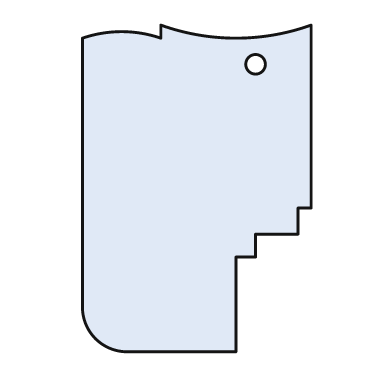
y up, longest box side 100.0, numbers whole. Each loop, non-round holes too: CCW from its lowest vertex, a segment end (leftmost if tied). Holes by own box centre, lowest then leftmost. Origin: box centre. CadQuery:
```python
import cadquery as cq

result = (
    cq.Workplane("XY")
    .moveTo(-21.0, -50.0)
    .lineTo(12.0, -50.0)
    .lineTo(12.0, -21.0)
    .lineTo(18.0, -21.0)
    .lineTo(18.0, -14.0)
    .lineTo(31.0, -14.0)
    .lineTo(31.0, -6.0)
    .lineTo(35.0, -6.0)
    .lineTo(35.0, 50.0)
    .threePointArc((12.0, 46.0), (-11.0, 50.0))
    .lineTo(-11.0, 46.0)
    .threePointArc((-23.0, 48.0), (-35.0, 46.0))
    .lineTo(-35.0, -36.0)
    .threePointArc((-31.0, -46.0), (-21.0, -50.0))
    .close()
    .moveTo(18.0, 38.0)
    .circle(3.0)
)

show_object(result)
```